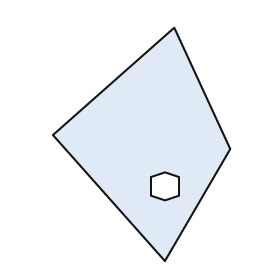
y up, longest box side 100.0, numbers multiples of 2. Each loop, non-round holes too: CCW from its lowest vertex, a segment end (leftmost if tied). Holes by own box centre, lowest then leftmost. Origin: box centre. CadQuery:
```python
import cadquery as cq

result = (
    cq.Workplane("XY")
    .moveTo(10.0, -50.0)
    .lineTo(38.0, -2.0)
    .lineTo(14.0, 50.0)
    .lineTo(-38.0, 4.0)
    .close()
    .moveTo(10.0, -24.0)
    .lineTo(16.0, -22.0)
    .lineTo(16.0, -14.0)
    .lineTo(10.0, -12.0)
    .lineTo(4.0, -14.0)
    .lineTo(4.0, -22.0)
    .close()
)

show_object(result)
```